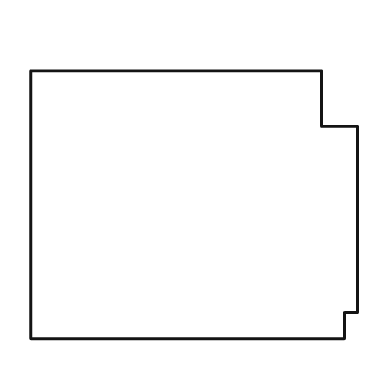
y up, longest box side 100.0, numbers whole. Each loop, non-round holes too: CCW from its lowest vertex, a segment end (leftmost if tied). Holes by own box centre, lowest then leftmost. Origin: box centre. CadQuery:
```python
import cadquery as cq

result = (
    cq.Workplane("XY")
    .moveTo(-50.0, -41.0)
    .lineTo(46.0, -41.0)
    .lineTo(46.0, -33.0)
    .lineTo(50.0, -33.0)
    .lineTo(50.0, 24.0)
    .lineTo(39.0, 24.0)
    .lineTo(39.0, 41.0)
    .lineTo(-50.0, 41.0)
    .close()
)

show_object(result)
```